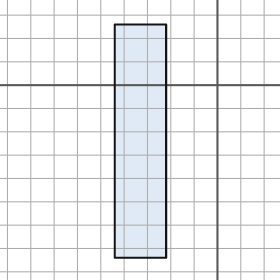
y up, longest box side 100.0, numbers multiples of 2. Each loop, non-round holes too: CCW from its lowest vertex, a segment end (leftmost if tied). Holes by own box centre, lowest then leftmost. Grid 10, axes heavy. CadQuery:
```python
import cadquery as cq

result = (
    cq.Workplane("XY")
    .moveTo(-44.0, -74.0)
    .lineTo(-22.0, -74.0)
    .lineTo(-22.0, 26.0)
    .lineTo(-44.0, 26.0)
    .close()
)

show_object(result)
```